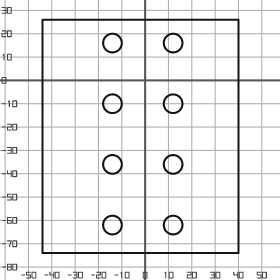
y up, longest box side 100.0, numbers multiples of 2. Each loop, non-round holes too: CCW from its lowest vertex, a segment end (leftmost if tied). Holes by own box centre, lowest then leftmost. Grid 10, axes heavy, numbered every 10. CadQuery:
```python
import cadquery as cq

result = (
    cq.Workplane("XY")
    .moveTo(-44.0, -74.0)
    .lineTo(40.0, -74.0)
    .lineTo(40.0, 26.0)
    .lineTo(-44.0, 26.0)
    .close()
    .moveTo(-14.0, -62.0)
    .circle(4.0)
    .moveTo(12.0, -62.0)
    .circle(4.0)
    .moveTo(-14.0, -36.0)
    .circle(4.0)
    .moveTo(12.0, -36.0)
    .circle(4.0)
    .moveTo(-14.0, -10.0)
    .circle(4.0)
    .moveTo(12.0, -10.0)
    .circle(4.0)
    .moveTo(-14.0, 16.0)
    .circle(4.0)
    .moveTo(12.0, 16.0)
    .circle(4.0)
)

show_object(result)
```